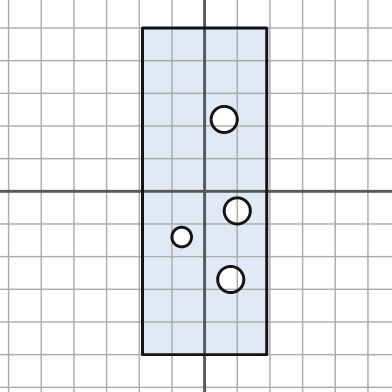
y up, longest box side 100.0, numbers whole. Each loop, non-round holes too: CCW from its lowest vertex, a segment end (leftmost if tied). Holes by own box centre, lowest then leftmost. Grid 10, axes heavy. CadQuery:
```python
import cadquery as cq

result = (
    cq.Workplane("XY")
    .moveTo(-19.0, -50.0)
    .lineTo(19.0, -50.0)
    .lineTo(19.0, 50.0)
    .lineTo(-19.0, 50.0)
    .close()
    .moveTo(8.0, -27.0)
    .circle(4.0)
    .moveTo(-7.0, -14.0)
    .circle(3.0)
    .moveTo(10.0, -6.0)
    .circle(4.0)
    .moveTo(6.0, 22.0)
    .circle(4.0)
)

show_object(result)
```